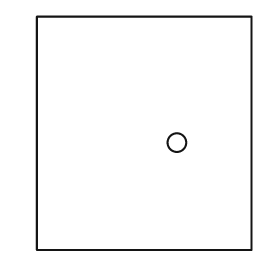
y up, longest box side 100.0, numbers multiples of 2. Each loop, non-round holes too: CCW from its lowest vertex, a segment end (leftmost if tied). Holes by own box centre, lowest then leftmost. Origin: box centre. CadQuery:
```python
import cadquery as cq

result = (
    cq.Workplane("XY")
    .moveTo(-46.0, -50.0)
    .lineTo(46.0, -50.0)
    .lineTo(46.0, 50.0)
    .lineTo(-46.0, 50.0)
    .close()
    .moveTo(14.0, -4.0)
    .circle(4.0)
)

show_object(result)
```